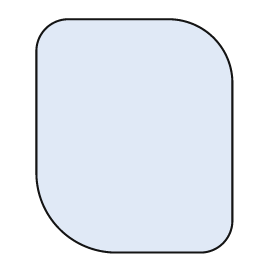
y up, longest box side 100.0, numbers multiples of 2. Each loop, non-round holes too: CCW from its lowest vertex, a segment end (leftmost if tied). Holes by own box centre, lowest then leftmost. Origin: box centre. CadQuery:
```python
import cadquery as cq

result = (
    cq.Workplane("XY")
    .moveTo(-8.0, -50.0)
    .lineTo(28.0, -50.0)
    .threePointArc((38.0, -46.0), (42.0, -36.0))
    .lineTo(42.0, 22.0)
    .threePointArc((34.0, 42.0), (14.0, 50.0))
    .lineTo(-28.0, 50.0)
    .threePointArc((-38.0, 46.0), (-42.0, 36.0))
    .lineTo(-42.0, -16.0)
    .threePointArc((-32.0, -40.0), (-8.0, -50.0))
    .close()
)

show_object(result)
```